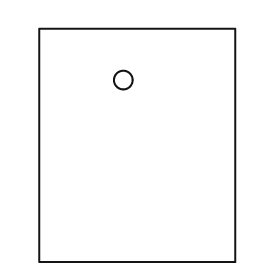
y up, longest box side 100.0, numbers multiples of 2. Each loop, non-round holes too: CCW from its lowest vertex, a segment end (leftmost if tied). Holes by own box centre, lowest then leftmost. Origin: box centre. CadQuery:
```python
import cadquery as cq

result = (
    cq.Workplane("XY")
    .moveTo(-42.0, -50.0)
    .lineTo(42.0, -50.0)
    .lineTo(42.0, 50.0)
    .lineTo(-42.0, 50.0)
    .close()
    .moveTo(-6.0, 28.0)
    .circle(4.0)
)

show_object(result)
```